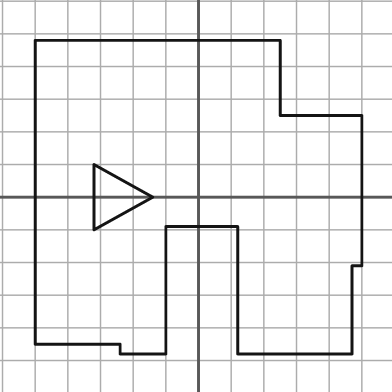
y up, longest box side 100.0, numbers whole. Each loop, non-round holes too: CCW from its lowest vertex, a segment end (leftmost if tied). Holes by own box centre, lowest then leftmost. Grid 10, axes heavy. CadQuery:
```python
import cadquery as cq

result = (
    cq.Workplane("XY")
    .moveTo(-24.0, -48.0)
    .lineTo(-10.0, -48.0)
    .lineTo(-10.0, -9.0)
    .lineTo(12.0, -9.0)
    .lineTo(12.0, -48.0)
    .lineTo(47.0, -48.0)
    .lineTo(47.0, -21.0)
    .lineTo(50.0, -21.0)
    .lineTo(50.0, 25.0)
    .lineTo(25.0, 25.0)
    .lineTo(25.0, 48.0)
    .lineTo(-50.0, 48.0)
    .lineTo(-50.0, -45.0)
    .lineTo(-24.0, -45.0)
    .close()
    .moveTo(-32.0, -10.0)
    .lineTo(-14.0, 0.0)
    .lineTo(-32.0, 10.0)
    .close()
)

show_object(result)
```